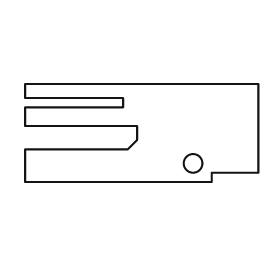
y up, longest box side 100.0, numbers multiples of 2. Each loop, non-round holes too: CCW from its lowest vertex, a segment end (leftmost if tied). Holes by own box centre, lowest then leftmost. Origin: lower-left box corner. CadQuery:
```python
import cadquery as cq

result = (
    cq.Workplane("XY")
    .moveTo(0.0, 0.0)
    .lineTo(80.0, 0.0)
    .lineTo(80.0, 4.0)
    .lineTo(100.0, 4.0)
    .lineTo(100.0, 42.0)
    .lineTo(0.0, 42.0)
    .lineTo(0.0, 36.0)
    .lineTo(42.0, 36.0)
    .lineTo(42.0, 32.0)
    .lineTo(0.0, 32.0)
    .lineTo(0.0, 24.0)
    .lineTo(48.0, 24.0)
    .lineTo(48.0, 18.0)
    .lineTo(44.0, 14.0)
    .lineTo(0.0, 14.0)
    .close()
    .moveTo(72.0, 8.0)
    .circle(4.0)
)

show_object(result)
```